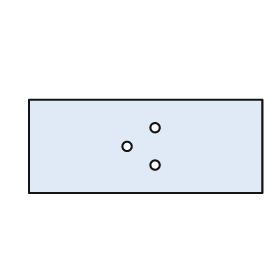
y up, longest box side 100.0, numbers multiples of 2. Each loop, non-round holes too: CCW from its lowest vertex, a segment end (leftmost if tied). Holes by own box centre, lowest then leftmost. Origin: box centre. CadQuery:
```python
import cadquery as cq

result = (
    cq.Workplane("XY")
    .moveTo(-50.0, -20.0)
    .lineTo(50.0, -20.0)
    .lineTo(50.0, 20.0)
    .lineTo(-50.0, 20.0)
    .close()
    .moveTo(4.0, -8.0)
    .circle(2.0)
    .moveTo(-8.0, 0.0)
    .circle(2.0)
    .moveTo(4.0, 8.0)
    .circle(2.0)
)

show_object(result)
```